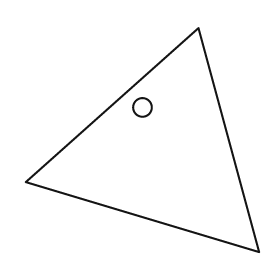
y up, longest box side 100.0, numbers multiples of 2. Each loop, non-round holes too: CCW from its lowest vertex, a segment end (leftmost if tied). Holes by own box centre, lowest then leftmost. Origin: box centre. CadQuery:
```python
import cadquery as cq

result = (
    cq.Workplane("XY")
    .moveTo(50.0, -48.0)
    .lineTo(24.0, 48.0)
    .lineTo(-50.0, -18.0)
    .close()
    .moveTo(0.0, 14.0)
    .circle(4.0)
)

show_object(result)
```